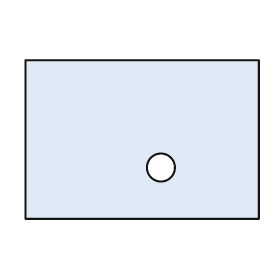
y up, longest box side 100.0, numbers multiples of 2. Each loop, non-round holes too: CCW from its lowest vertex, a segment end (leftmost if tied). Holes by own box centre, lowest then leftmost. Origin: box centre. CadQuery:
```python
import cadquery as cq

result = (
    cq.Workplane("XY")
    .moveTo(-50.0, -34.0)
    .lineTo(50.0, -34.0)
    .lineTo(50.0, 34.0)
    .lineTo(-50.0, 34.0)
    .close()
    .moveTo(8.0, -12.0)
    .circle(6.0)
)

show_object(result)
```